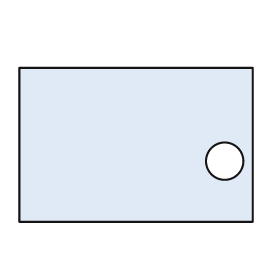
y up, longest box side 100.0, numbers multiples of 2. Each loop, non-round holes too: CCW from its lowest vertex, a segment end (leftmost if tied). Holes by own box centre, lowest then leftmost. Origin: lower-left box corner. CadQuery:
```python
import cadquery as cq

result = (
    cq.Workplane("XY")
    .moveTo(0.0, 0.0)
    .lineTo(100.0, 0.0)
    .lineTo(100.0, 66.0)
    .lineTo(0.0, 66.0)
    .close()
    .moveTo(88.0, 26.0)
    .circle(8.0)
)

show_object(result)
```